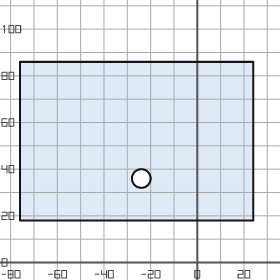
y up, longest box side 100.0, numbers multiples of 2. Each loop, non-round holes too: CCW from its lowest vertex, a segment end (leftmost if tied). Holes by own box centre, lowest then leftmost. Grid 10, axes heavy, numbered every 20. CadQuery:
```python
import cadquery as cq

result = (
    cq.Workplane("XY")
    .moveTo(-76.0, 18.0)
    .lineTo(24.0, 18.0)
    .lineTo(24.0, 86.0)
    .lineTo(-76.0, 86.0)
    .close()
    .moveTo(-24.0, 36.0)
    .circle(4.0)
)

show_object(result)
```